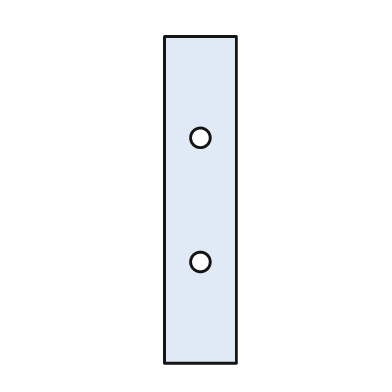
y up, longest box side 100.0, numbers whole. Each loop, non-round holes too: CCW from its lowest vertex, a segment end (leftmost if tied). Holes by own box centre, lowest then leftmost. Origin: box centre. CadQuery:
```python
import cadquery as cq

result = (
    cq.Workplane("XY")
    .moveTo(-11.0, -50.0)
    .lineTo(11.0, -50.0)
    .lineTo(11.0, 50.0)
    .lineTo(-11.0, 50.0)
    .close()
    .moveTo(0.0, -19.0)
    .circle(3.0)
    .moveTo(0.0, 19.0)
    .circle(3.0)
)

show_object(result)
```